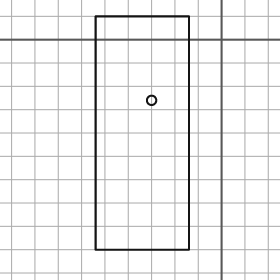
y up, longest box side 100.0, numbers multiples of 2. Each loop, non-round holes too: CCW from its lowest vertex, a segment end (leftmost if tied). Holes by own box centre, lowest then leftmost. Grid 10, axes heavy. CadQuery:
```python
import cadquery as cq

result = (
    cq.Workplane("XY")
    .moveTo(-54.0, -90.0)
    .lineTo(-14.0, -90.0)
    .lineTo(-14.0, 10.0)
    .lineTo(-54.0, 10.0)
    .close()
    .moveTo(-30.0, -26.0)
    .circle(2.0)
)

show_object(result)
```